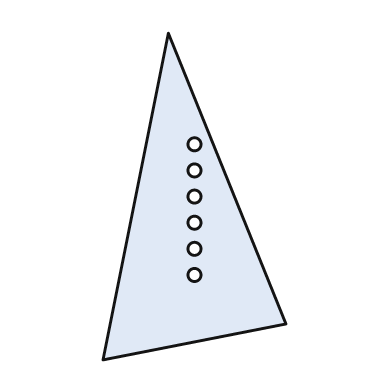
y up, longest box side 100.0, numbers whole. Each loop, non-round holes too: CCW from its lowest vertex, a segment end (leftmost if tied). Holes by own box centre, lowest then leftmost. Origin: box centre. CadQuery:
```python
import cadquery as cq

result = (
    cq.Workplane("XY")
    .moveTo(-28.0, -50.0)
    .lineTo(28.0, -39.0)
    .lineTo(-8.0, 50.0)
    .close()
    .moveTo(0.0, -24.0)
    .circle(2.0)
    .moveTo(0.0, -16.0)
    .circle(2.0)
    .moveTo(0.0, -8.0)
    .circle(2.0)
    .moveTo(0.0, 0.0)
    .circle(2.0)
    .moveTo(0.0, 8.0)
    .circle(2.0)
    .moveTo(0.0, 16.0)
    .circle(2.0)
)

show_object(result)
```